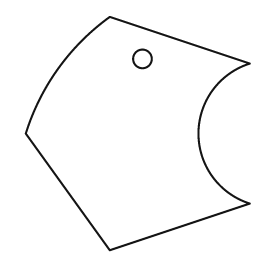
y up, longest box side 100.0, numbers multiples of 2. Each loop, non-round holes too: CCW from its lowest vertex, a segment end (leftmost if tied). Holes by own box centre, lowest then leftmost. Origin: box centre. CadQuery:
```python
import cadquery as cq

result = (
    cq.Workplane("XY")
    .moveTo(-12.0, -50.0)
    .lineTo(48.0, -30.0)
    .threePointArc((26.0, 0.0), (48.0, 30.0))
    .lineTo(-12.0, 50.0)
    .threePointArc((-34.0, 28.0), (-48.0, 0.0))
    .close()
    .moveTo(2.0, 32.0)
    .circle(4.0)
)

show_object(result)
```